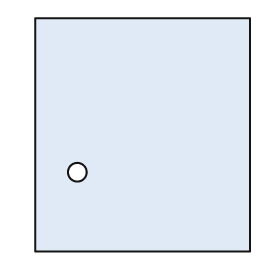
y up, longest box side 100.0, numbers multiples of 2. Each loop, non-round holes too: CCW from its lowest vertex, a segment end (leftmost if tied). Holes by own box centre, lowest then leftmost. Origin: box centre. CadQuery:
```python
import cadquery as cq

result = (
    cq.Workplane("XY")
    .moveTo(-46.0, -50.0)
    .lineTo(46.0, -50.0)
    .lineTo(46.0, 50.0)
    .lineTo(-46.0, 50.0)
    .close()
    .moveTo(-28.0, -16.0)
    .circle(4.0)
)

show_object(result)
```